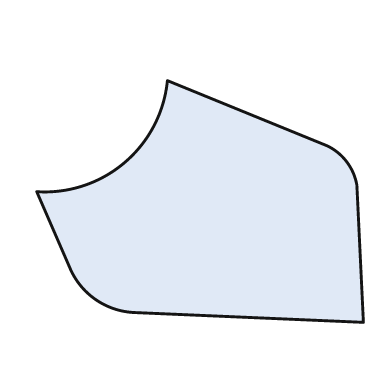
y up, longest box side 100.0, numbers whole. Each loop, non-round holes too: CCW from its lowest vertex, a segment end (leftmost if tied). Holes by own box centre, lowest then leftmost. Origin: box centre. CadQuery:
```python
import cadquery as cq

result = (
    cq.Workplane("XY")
    .moveTo(50.0, -37.0)
    .lineTo(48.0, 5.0)
    .threePointArc((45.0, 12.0), (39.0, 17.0))
    .lineTo(-10.0, 37.0)
    .threePointArc((-23.0, 12.0), (-50.0, 3.0))
    .lineTo(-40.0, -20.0)
    .threePointArc((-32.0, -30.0), (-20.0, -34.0))
    .close()
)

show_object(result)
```